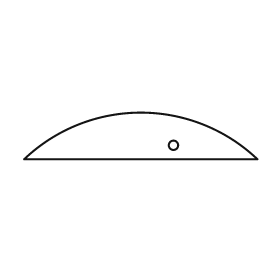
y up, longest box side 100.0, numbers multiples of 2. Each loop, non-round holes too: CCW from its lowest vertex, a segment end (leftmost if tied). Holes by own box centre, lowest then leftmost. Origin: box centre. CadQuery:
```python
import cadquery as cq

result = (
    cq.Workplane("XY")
    .moveTo(-50.0, -10.0)
    .lineTo(50.0, -10.0)
    .threePointArc((0.0, 10.0), (-50.0, -10.0))
    .close()
    .moveTo(14.0, -4.0)
    .circle(2.0)
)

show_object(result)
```